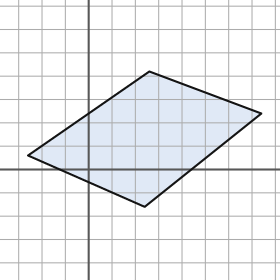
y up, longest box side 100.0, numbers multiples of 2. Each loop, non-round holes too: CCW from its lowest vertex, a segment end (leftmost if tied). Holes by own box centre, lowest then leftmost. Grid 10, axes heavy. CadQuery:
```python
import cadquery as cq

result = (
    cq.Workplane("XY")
    .moveTo(24.0, -16.0)
    .lineTo(74.0, 24.0)
    .lineTo(26.0, 42.0)
    .lineTo(-26.0, 6.0)
    .close()
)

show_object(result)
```